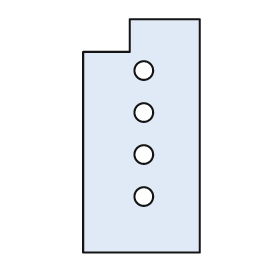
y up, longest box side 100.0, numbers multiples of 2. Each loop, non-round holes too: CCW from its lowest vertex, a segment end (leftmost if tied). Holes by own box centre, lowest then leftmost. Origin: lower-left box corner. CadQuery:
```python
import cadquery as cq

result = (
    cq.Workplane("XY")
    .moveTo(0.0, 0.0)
    .lineTo(50.0, 0.0)
    .lineTo(50.0, 100.0)
    .lineTo(20.0, 100.0)
    .lineTo(20.0, 86.0)
    .lineTo(0.0, 86.0)
    .close()
    .moveTo(26.0, 24.0)
    .circle(4.0)
    .moveTo(26.0, 42.0)
    .circle(4.0)
    .moveTo(26.0, 60.0)
    .circle(4.0)
    .moveTo(26.0, 78.0)
    .circle(4.0)
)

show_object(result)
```